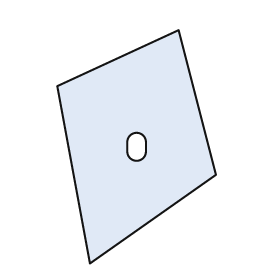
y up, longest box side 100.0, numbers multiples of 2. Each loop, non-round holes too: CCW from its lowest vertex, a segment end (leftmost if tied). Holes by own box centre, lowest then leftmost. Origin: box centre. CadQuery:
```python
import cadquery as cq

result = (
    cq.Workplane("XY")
    .moveTo(-20.0, -50.0)
    .lineTo(34.0, -12.0)
    .lineTo(18.0, 50.0)
    .lineTo(-34.0, 26.0)
    .close()
    .moveTo(-4.0, -2.0)
    .threePointArc((0.0, -6.0), (4.0, -2.0))
    .lineTo(4.0, 2.0)
    .threePointArc((0.0, 6.0), (-4.0, 2.0))
    .close()
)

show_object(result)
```